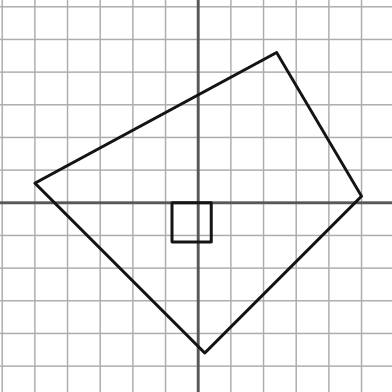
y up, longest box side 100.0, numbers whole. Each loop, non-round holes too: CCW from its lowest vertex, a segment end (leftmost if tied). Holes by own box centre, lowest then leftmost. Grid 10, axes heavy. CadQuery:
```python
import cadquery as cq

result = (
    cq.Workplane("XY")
    .moveTo(2.0, -46.0)
    .lineTo(50.0, 2.0)
    .lineTo(24.0, 46.0)
    .lineTo(-50.0, 6.0)
    .close()
    .moveTo(-8.0, -12.0)
    .lineTo(4.0, -12.0)
    .lineTo(4.0, 0.0)
    .lineTo(-8.0, 0.0)
    .close()
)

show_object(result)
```